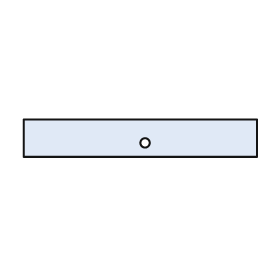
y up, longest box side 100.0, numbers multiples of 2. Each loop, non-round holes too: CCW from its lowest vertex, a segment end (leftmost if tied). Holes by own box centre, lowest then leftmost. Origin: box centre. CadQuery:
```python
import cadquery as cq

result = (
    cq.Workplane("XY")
    .moveTo(-50.0, -8.0)
    .lineTo(50.0, -8.0)
    .lineTo(50.0, 8.0)
    .lineTo(-50.0, 8.0)
    .close()
    .moveTo(2.0, -2.0)
    .circle(2.0)
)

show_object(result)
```